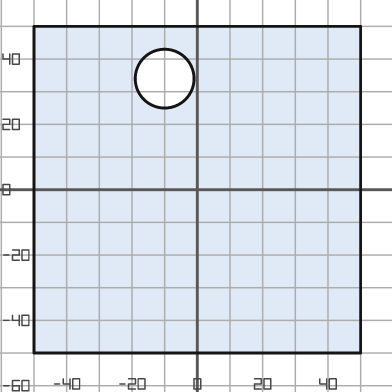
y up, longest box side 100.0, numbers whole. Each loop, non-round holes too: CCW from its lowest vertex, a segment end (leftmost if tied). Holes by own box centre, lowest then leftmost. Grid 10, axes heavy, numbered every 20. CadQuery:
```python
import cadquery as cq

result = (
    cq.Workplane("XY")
    .moveTo(-50.0, -50.0)
    .lineTo(50.0, -50.0)
    .lineTo(50.0, 50.0)
    .lineTo(-50.0, 50.0)
    .close()
    .moveTo(-10.0, 34.0)
    .circle(9.0)
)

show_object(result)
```